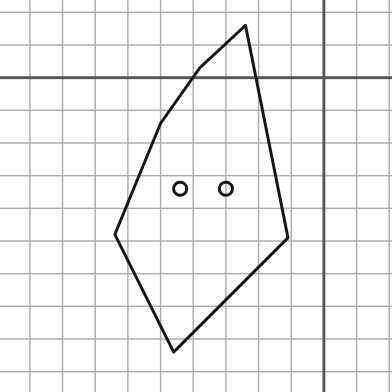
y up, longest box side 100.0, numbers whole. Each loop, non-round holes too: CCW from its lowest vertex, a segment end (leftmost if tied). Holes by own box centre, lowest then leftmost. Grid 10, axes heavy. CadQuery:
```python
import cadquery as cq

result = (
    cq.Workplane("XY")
    .moveTo(-46.0, -84.0)
    .lineTo(-11.0, -49.0)
    .lineTo(-24.0, 16.0)
    .lineTo(-38.0, 3.0)
    .lineTo(-50.0, -14.0)
    .lineTo(-64.0, -48.0)
    .close()
    .moveTo(-44.0, -34.0)
    .circle(2.0)
    .moveTo(-30.0, -34.0)
    .circle(2.0)
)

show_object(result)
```